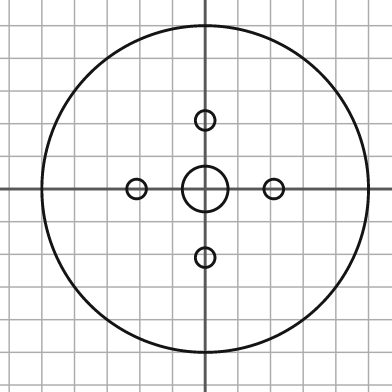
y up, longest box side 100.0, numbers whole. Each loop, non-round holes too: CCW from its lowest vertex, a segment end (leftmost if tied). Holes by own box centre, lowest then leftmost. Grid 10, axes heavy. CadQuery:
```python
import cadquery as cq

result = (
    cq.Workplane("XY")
    .moveTo(0.0, 0.0)
    .circle(50.0)
    .moveTo(0.0, -21.0)
    .circle(3.0)
    .moveTo(-21.0, 0.0)
    .circle(3.0)
    .moveTo(0.0, 0.0)
    .circle(7.0)
    .moveTo(21.0, 0.0)
    .circle(3.0)
    .moveTo(0.0, 21.0)
    .circle(3.0)
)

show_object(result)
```